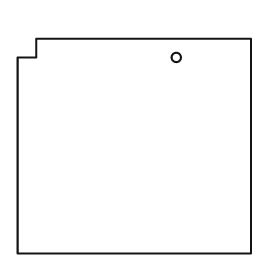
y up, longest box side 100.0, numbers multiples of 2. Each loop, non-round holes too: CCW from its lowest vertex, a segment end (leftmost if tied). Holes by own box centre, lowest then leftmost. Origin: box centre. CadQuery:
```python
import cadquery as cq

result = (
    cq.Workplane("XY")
    .moveTo(-50.0, -46.0)
    .lineTo(50.0, -46.0)
    .lineTo(50.0, 46.0)
    .lineTo(-42.0, 46.0)
    .lineTo(-42.0, 38.0)
    .lineTo(-50.0, 38.0)
    .close()
    .moveTo(18.0, 38.0)
    .circle(2.0)
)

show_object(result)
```